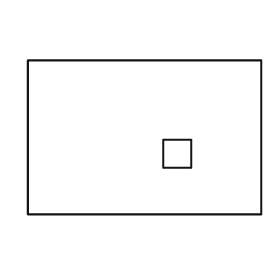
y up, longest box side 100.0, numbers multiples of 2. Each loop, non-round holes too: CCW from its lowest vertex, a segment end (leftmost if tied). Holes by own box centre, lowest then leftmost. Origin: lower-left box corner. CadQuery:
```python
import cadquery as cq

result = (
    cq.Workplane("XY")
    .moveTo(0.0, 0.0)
    .lineTo(100.0, 0.0)
    .lineTo(100.0, 66.0)
    .lineTo(0.0, 66.0)
    .close()
    .moveTo(58.0, 20.0)
    .lineTo(70.0, 20.0)
    .lineTo(70.0, 32.0)
    .lineTo(58.0, 32.0)
    .close()
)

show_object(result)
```